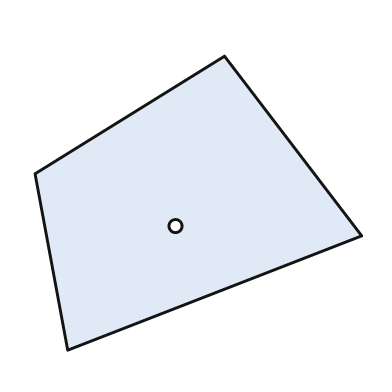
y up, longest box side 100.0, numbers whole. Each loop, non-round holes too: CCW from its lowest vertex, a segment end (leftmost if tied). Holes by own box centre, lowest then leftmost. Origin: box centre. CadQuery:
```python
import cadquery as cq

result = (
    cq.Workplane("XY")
    .moveTo(-40.0, -45.0)
    .lineTo(50.0, -10.0)
    .lineTo(8.0, 45.0)
    .lineTo(-50.0, 9.0)
    .close()
    .moveTo(-7.0, -7.0)
    .circle(2.0)
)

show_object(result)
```